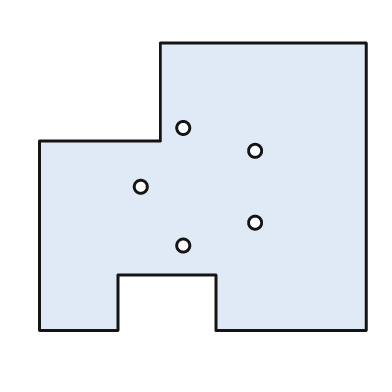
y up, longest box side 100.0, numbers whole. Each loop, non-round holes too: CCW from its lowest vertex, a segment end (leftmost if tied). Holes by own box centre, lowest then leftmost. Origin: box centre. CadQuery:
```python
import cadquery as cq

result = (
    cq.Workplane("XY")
    .moveTo(-50.0, -44.0)
    .lineTo(-26.0, -44.0)
    .lineTo(-26.0, -27.0)
    .lineTo(4.0, -27.0)
    .lineTo(4.0, -44.0)
    .lineTo(50.0, -44.0)
    .lineTo(50.0, 44.0)
    .lineTo(-13.0, 44.0)
    .lineTo(-13.0, 14.0)
    .lineTo(-50.0, 14.0)
    .close()
    .moveTo(-6.0, -18.0)
    .circle(2.0)
    .moveTo(16.0, -11.0)
    .circle(2.0)
    .moveTo(-19.0, 0.0)
    .circle(2.0)
    .moveTo(16.0, 11.0)
    .circle(2.0)
    .moveTo(-6.0, 18.0)
    .circle(2.0)
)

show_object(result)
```